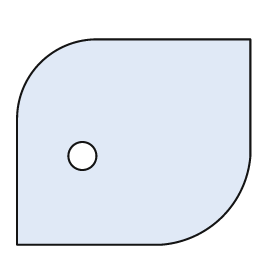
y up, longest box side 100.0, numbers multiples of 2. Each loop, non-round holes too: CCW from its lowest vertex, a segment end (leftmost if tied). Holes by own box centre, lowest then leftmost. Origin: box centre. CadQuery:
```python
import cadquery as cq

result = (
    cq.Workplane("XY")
    .moveTo(-50.0, -44.0)
    .lineTo(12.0, -44.0)
    .threePointArc((38.0, -32.0), (50.0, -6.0))
    .lineTo(50.0, 44.0)
    .lineTo(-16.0, 44.0)
    .threePointArc((-40.0, 34.0), (-50.0, 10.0))
    .close()
    .moveTo(-22.0, -6.0)
    .circle(6.0)
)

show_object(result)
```